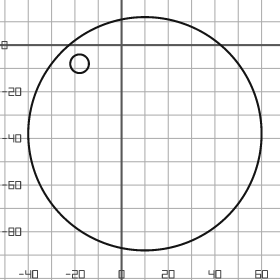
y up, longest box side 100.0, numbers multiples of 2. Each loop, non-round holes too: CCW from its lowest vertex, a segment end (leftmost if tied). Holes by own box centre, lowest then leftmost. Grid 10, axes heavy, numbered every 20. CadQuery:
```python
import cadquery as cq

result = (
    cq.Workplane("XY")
    .moveTo(10.0, -38.0)
    .circle(50.0)
    .moveTo(-18.0, -8.0)
    .circle(4.0)
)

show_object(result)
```